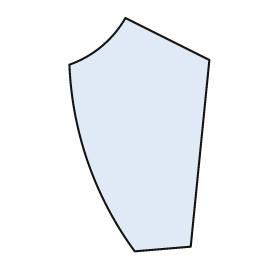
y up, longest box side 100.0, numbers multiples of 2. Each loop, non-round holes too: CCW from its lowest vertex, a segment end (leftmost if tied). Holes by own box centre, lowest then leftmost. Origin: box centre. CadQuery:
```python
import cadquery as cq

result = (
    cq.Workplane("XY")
    .moveTo(-2.0, -50.0)
    .lineTo(22.0, -48.0)
    .lineTo(30.0, 32.0)
    .lineTo(-6.0, 50.0)
    .threePointArc((-16.0, 38.0), (-30.0, 30.0))
    .threePointArc((-22.0, -12.0), (-2.0, -50.0))
    .close()
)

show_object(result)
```